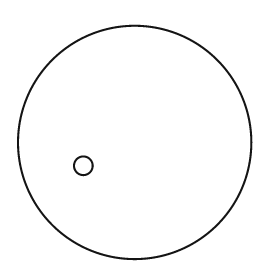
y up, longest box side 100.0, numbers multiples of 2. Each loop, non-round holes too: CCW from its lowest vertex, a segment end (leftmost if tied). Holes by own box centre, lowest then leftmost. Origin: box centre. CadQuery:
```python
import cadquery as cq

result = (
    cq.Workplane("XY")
    .moveTo(0.0, 0.0)
    .circle(50.0)
    .moveTo(-22.0, -10.0)
    .circle(4.0)
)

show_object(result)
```